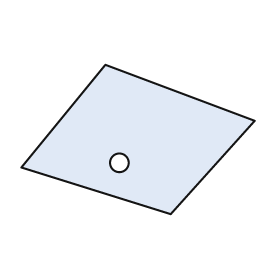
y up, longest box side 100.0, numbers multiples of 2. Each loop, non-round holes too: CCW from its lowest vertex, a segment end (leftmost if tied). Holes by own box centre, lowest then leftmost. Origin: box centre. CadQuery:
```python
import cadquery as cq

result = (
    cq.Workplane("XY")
    .moveTo(14.0, -32.0)
    .lineTo(50.0, 8.0)
    .lineTo(-14.0, 32.0)
    .lineTo(-50.0, -12.0)
    .close()
    .moveTo(-8.0, -10.0)
    .circle(4.0)
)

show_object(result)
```